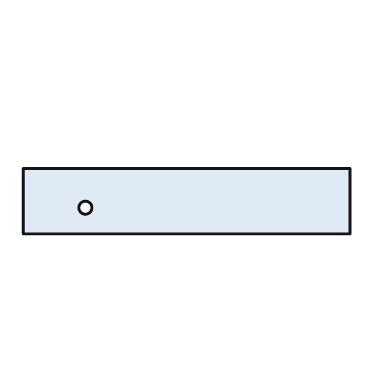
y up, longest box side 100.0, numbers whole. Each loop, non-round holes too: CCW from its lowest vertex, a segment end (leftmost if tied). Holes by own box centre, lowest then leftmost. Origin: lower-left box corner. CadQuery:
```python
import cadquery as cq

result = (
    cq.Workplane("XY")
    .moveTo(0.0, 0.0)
    .lineTo(100.0, 0.0)
    .lineTo(100.0, 20.0)
    .lineTo(0.0, 20.0)
    .close()
    .moveTo(19.0, 8.0)
    .circle(2.0)
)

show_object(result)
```